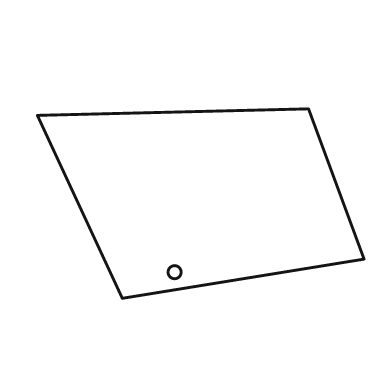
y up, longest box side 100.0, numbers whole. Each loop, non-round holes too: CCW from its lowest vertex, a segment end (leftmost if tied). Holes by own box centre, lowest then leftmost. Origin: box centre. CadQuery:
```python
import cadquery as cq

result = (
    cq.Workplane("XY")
    .moveTo(-24.0, -29.0)
    .lineTo(50.0, -17.0)
    .lineTo(33.0, 29.0)
    .lineTo(-50.0, 27.0)
    .close()
    .moveTo(-8.0, -21.0)
    .circle(2.0)
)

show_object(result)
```